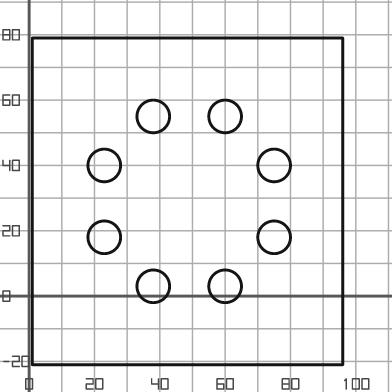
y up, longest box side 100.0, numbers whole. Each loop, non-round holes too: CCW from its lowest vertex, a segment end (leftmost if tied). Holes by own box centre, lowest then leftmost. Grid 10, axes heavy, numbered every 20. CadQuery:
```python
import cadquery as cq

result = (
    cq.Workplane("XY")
    .moveTo(1.0, -21.0)
    .lineTo(96.0, -21.0)
    .lineTo(96.0, 79.0)
    .lineTo(1.0, 79.0)
    .close()
    .moveTo(38.0, 3.0)
    .circle(5.0)
    .moveTo(60.0, 3.0)
    .circle(5.0)
    .moveTo(23.0, 18.0)
    .circle(5.0)
    .moveTo(75.0, 18.0)
    .circle(5.0)
    .moveTo(23.0, 40.0)
    .circle(5.0)
    .moveTo(75.0, 40.0)
    .circle(5.0)
    .moveTo(38.0, 55.0)
    .circle(5.0)
    .moveTo(60.0, 55.0)
    .circle(5.0)
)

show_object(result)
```